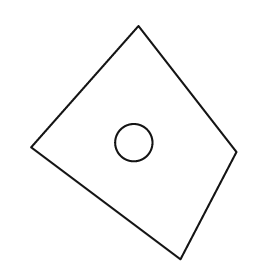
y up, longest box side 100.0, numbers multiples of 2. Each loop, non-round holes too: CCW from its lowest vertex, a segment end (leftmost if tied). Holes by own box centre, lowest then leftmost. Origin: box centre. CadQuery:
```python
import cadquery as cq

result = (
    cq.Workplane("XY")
    .moveTo(20.0, -50.0)
    .lineTo(44.0, -4.0)
    .lineTo(2.0, 50.0)
    .lineTo(-44.0, -2.0)
    .close()
    .moveTo(0.0, 0.0)
    .circle(8.0)
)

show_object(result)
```